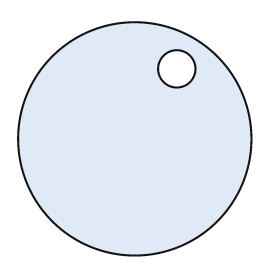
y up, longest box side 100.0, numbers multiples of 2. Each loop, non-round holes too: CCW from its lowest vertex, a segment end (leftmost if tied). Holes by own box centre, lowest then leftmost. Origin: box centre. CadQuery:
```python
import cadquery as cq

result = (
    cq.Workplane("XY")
    .moveTo(0.0, 0.0)
    .circle(50.0)
    .moveTo(18.0, 30.0)
    .circle(8.0)
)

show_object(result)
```